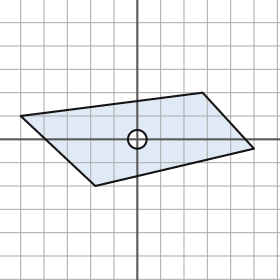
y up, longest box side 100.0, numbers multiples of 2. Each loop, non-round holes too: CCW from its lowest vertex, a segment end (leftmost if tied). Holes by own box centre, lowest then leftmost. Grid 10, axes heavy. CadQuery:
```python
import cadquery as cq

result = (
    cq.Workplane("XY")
    .moveTo(-18.0, -20.0)
    .lineTo(50.0, -4.0)
    .lineTo(28.0, 20.0)
    .lineTo(-50.0, 10.0)
    .close()
    .moveTo(0.0, 0.0)
    .circle(4.0)
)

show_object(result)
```